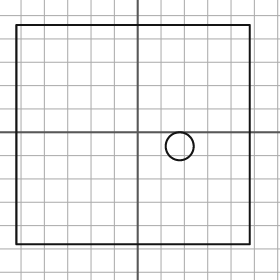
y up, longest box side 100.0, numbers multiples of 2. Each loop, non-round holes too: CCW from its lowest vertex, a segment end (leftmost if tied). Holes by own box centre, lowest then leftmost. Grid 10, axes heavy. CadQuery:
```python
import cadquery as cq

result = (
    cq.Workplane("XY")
    .moveTo(-52.0, -48.0)
    .lineTo(48.0, -48.0)
    .lineTo(48.0, 46.0)
    .lineTo(-52.0, 46.0)
    .close()
    .moveTo(18.0, -6.0)
    .circle(6.0)
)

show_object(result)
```